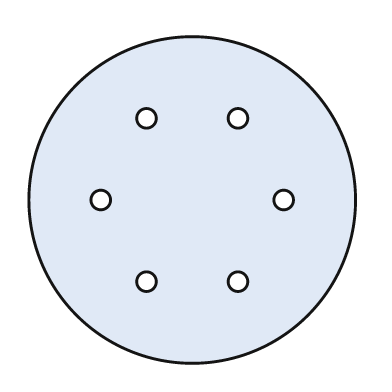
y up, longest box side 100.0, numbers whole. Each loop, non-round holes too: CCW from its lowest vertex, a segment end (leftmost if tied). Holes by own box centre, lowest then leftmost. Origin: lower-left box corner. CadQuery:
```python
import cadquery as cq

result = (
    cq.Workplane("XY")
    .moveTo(50.0, 50.0)
    .circle(50.0)
    .moveTo(36.0, 25.0)
    .circle(3.0)
    .moveTo(64.0, 25.0)
    .circle(3.0)
    .moveTo(22.0, 50.0)
    .circle(3.0)
    .moveTo(78.0, 50.0)
    .circle(3.0)
    .moveTo(36.0, 75.0)
    .circle(3.0)
    .moveTo(64.0, 75.0)
    .circle(3.0)
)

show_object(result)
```